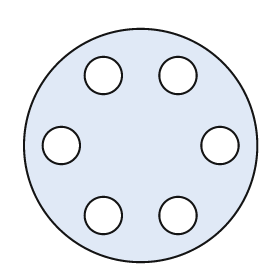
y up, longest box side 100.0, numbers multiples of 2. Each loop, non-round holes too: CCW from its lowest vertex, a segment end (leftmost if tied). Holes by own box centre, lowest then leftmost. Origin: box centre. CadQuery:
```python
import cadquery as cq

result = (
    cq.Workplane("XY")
    .moveTo(0.0, 0.0)
    .circle(50.0)
    .moveTo(-16.0, -30.0)
    .circle(8.0)
    .moveTo(16.0, -30.0)
    .circle(8.0)
    .moveTo(-34.0, 0.0)
    .circle(8.0)
    .moveTo(34.0, 0.0)
    .circle(8.0)
    .moveTo(-16.0, 30.0)
    .circle(8.0)
    .moveTo(16.0, 30.0)
    .circle(8.0)
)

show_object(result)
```